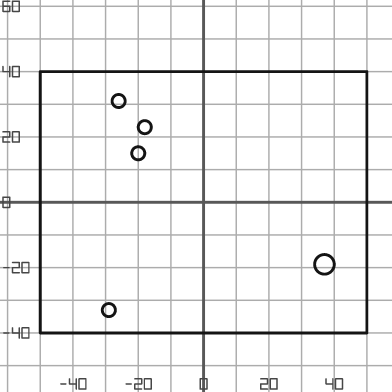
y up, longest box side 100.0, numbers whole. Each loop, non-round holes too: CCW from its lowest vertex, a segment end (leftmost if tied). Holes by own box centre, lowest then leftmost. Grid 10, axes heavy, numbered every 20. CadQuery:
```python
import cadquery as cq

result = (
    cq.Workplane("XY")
    .moveTo(-50.0, -40.0)
    .lineTo(50.0, -40.0)
    .lineTo(50.0, 40.0)
    .lineTo(-50.0, 40.0)
    .close()
    .moveTo(-29.0, -33.0)
    .circle(2.0)
    .moveTo(37.0, -19.0)
    .circle(3.0)
    .moveTo(-20.0, 15.0)
    .circle(2.0)
    .moveTo(-18.0, 23.0)
    .circle(2.0)
    .moveTo(-26.0, 31.0)
    .circle(2.0)
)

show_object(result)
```